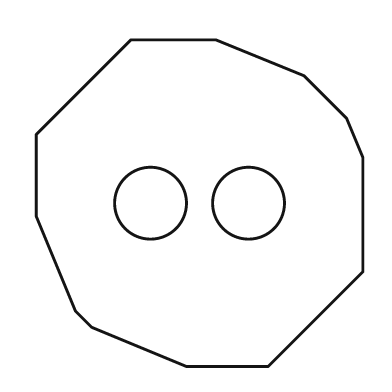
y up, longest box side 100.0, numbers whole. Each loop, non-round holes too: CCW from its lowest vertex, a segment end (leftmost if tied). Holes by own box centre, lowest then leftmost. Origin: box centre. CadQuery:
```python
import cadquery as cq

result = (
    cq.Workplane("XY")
    .moveTo(-4.0, -50.0)
    .lineTo(21.0, -50.0)
    .lineTo(50.0, -21.0)
    .lineTo(50.0, 14.0)
    .lineTo(45.0, 26.0)
    .lineTo(32.0, 39.0)
    .lineTo(5.0, 50.0)
    .lineTo(-21.0, 50.0)
    .lineTo(-50.0, 21.0)
    .lineTo(-50.0, -4.0)
    .lineTo(-38.0, -33.0)
    .lineTo(-33.0, -38.0)
    .close()
    .moveTo(-15.0, 0.0)
    .circle(11.0)
    .moveTo(15.0, 0.0)
    .circle(11.0)
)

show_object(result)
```